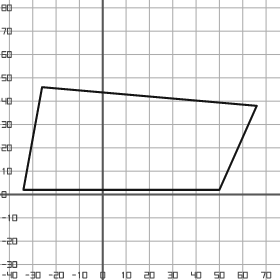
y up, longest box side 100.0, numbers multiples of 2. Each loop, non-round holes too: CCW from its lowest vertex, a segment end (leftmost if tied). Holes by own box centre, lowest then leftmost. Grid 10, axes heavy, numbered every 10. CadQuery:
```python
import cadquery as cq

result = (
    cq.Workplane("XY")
    .moveTo(-34.0, 2.0)
    .lineTo(50.0, 2.0)
    .lineTo(66.0, 38.0)
    .lineTo(-26.0, 46.0)
    .close()
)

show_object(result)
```